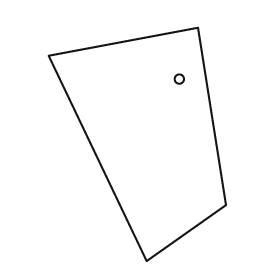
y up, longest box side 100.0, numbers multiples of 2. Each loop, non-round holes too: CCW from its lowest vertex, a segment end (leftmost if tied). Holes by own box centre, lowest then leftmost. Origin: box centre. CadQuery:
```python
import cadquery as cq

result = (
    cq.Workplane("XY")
    .moveTo(4.0, -50.0)
    .lineTo(38.0, -26.0)
    .lineTo(26.0, 50.0)
    .lineTo(-38.0, 38.0)
    .close()
    .moveTo(18.0, 28.0)
    .circle(2.0)
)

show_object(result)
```